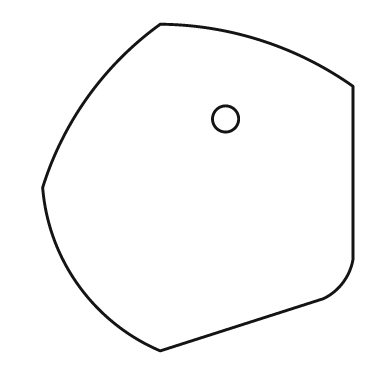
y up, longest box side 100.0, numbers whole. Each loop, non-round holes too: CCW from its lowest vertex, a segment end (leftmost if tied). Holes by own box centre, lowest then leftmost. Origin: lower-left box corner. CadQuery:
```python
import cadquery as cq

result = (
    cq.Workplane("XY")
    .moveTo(36.0, 0.0)
    .lineTo(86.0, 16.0)
    .threePointArc((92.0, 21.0), (95.0, 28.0))
    .lineTo(95.0, 81.0)
    .threePointArc((67.0, 95.0), (36.0, 100.0))
    .threePointArc((14.0, 78.0), (0.0, 50.0))
    .threePointArc((11.0, 20.0), (36.0, 0.0))
    .close()
    .moveTo(56.0, 71.0)
    .circle(4.0)
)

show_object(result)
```